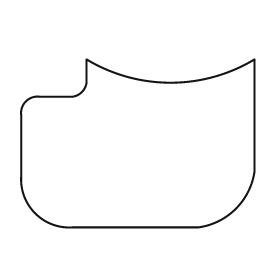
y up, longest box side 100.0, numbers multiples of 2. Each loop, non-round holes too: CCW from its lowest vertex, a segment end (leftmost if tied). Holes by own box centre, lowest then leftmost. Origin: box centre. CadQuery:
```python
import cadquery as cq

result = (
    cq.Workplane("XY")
    .moveTo(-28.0, -36.0)
    .lineTo(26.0, -36.0)
    .threePointArc((42.0, -28.0), (50.0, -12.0))
    .lineTo(50.0, 36.0)
    .threePointArc((14.0, 26.0), (-22.0, 36.0))
    .lineTo(-22.0, 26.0)
    .threePointArc((-24.0, 22.0), (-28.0, 20.0))
    .lineTo(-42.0, 20.0)
    .threePointArc((-48.0, 18.0), (-50.0, 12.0))
    .lineTo(-50.0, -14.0)
    .threePointArc((-44.0, -30.0), (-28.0, -36.0))
    .close()
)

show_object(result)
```